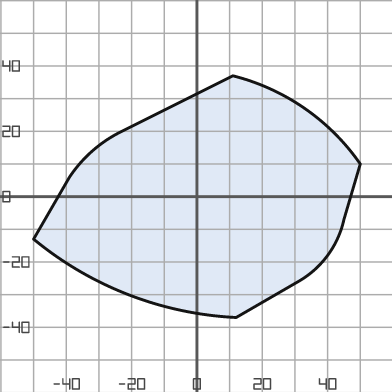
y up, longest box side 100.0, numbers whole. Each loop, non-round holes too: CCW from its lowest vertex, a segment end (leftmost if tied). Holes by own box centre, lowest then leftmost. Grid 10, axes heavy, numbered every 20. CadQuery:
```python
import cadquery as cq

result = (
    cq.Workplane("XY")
    .moveTo(12.0, -37.0)
    .lineTo(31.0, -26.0)
    .threePointArc((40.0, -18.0), (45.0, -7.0))
    .lineTo(50.0, 10.0)
    .threePointArc((33.0, 27.0), (11.0, 37.0))
    .lineTo(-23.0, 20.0)
    .threePointArc((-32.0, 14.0), (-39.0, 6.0))
    .lineTo(-50.0, -13.0)
    .threePointArc((-21.0, -30.0), (12.0, -37.0))
    .close()
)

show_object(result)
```